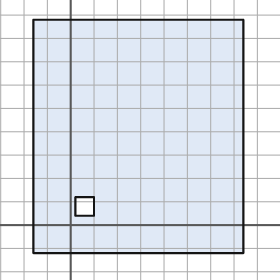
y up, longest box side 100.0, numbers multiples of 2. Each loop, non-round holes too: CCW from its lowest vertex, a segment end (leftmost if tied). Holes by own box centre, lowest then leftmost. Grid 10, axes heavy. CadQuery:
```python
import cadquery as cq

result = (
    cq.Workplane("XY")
    .moveTo(-16.0, -12.0)
    .lineTo(74.0, -12.0)
    .lineTo(74.0, 88.0)
    .lineTo(-16.0, 88.0)
    .close()
    .moveTo(2.0, 4.0)
    .lineTo(10.0, 4.0)
    .lineTo(10.0, 12.0)
    .lineTo(2.0, 12.0)
    .close()
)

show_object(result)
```